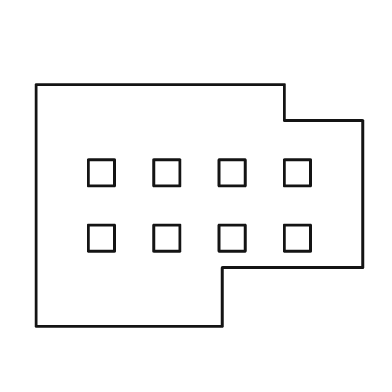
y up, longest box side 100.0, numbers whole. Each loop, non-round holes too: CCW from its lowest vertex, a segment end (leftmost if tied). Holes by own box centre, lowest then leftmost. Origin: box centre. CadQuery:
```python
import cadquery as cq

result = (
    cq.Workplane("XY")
    .moveTo(-50.0, -37.0)
    .lineTo(7.0, -37.0)
    .lineTo(7.0, -19.0)
    .lineTo(50.0, -19.0)
    .lineTo(50.0, 26.0)
    .lineTo(26.0, 26.0)
    .lineTo(26.0, 37.0)
    .lineTo(-50.0, 37.0)
    .close()
    .moveTo(-34.0, -14.0)
    .lineTo(-26.0, -14.0)
    .lineTo(-26.0, -6.0)
    .lineTo(-34.0, -6.0)
    .close()
    .moveTo(-14.0, -14.0)
    .lineTo(-6.0, -14.0)
    .lineTo(-6.0, -6.0)
    .lineTo(-14.0, -6.0)
    .close()
    .moveTo(6.0, -14.0)
    .lineTo(14.0, -14.0)
    .lineTo(14.0, -6.0)
    .lineTo(6.0, -6.0)
    .close()
    .moveTo(26.0, -14.0)
    .lineTo(34.0, -14.0)
    .lineTo(34.0, -6.0)
    .lineTo(26.0, -6.0)
    .close()
    .moveTo(-34.0, 6.0)
    .lineTo(-26.0, 6.0)
    .lineTo(-26.0, 14.0)
    .lineTo(-34.0, 14.0)
    .close()
    .moveTo(-14.0, 6.0)
    .lineTo(-6.0, 6.0)
    .lineTo(-6.0, 14.0)
    .lineTo(-14.0, 14.0)
    .close()
    .moveTo(6.0, 6.0)
    .lineTo(14.0, 6.0)
    .lineTo(14.0, 14.0)
    .lineTo(6.0, 14.0)
    .close()
    .moveTo(26.0, 6.0)
    .lineTo(34.0, 6.0)
    .lineTo(34.0, 14.0)
    .lineTo(26.0, 14.0)
    .close()
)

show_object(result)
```